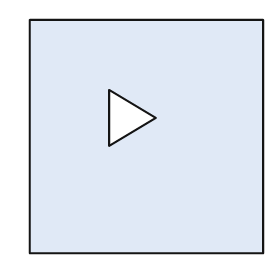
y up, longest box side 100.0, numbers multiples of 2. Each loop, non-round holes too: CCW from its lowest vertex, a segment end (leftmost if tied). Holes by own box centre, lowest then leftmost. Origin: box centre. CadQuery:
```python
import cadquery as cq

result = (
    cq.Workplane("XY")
    .moveTo(-50.0, -50.0)
    .lineTo(50.0, -50.0)
    .lineTo(50.0, 50.0)
    .lineTo(-50.0, 50.0)
    .close()
    .moveTo(-16.0, -4.0)
    .lineTo(4.0, 8.0)
    .lineTo(-16.0, 20.0)
    .close()
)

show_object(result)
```